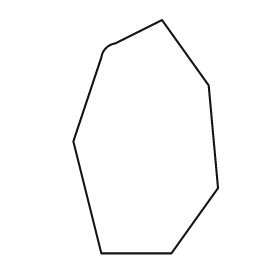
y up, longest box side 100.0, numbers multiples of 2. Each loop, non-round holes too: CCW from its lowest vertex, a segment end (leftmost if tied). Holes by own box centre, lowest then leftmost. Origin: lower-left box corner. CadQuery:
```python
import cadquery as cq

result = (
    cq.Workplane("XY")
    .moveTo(12.0, 0.0)
    .lineTo(42.0, 0.0)
    .lineTo(62.0, 28.0)
    .lineTo(58.0, 72.0)
    .lineTo(38.0, 100.0)
    .lineTo(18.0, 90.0)
    .threePointArc((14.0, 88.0), (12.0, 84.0))
    .lineTo(0.0, 48.0)
    .close()
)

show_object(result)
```